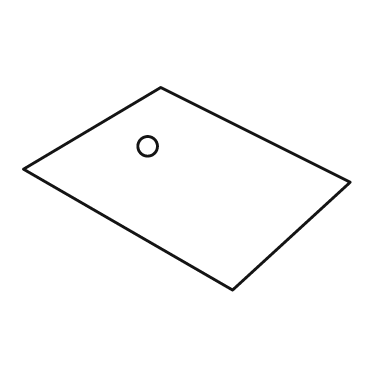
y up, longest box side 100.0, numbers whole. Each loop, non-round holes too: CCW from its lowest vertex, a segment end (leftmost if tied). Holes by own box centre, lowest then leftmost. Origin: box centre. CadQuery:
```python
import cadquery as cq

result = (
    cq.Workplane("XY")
    .moveTo(14.0, -31.0)
    .lineTo(50.0, 2.0)
    .lineTo(-8.0, 31.0)
    .lineTo(-50.0, 6.0)
    .close()
    .moveTo(-12.0, 13.0)
    .circle(3.0)
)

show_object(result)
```